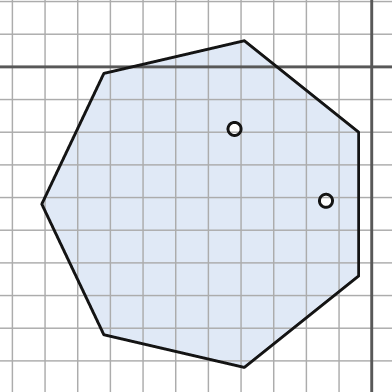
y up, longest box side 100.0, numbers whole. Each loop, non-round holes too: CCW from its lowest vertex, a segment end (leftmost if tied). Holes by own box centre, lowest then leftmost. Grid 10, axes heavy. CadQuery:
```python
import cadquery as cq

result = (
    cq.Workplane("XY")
    .moveTo(-39.0, -92.0)
    .lineTo(-4.0, -64.0)
    .lineTo(-4.0, -20.0)
    .lineTo(-39.0, 8.0)
    .lineTo(-82.0, -2.0)
    .lineTo(-101.0, -42.0)
    .lineTo(-82.0, -82.0)
    .close()
    .moveTo(-14.0, -41.0)
    .circle(2.0)
    .moveTo(-42.0, -19.0)
    .circle(2.0)
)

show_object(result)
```